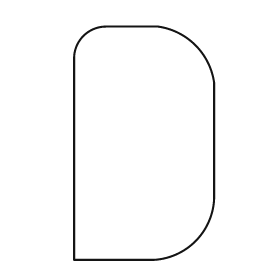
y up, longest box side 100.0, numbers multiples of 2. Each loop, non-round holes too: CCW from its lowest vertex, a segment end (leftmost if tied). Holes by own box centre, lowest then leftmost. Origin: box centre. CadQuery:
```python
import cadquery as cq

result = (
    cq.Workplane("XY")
    .moveTo(-30.0, -50.0)
    .lineTo(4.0, -50.0)
    .threePointArc((22.0, -42.0), (30.0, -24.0))
    .lineTo(30.0, 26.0)
    .threePointArc((22.0, 42.0), (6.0, 50.0))
    .lineTo(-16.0, 50.0)
    .threePointArc((-26.0, 46.0), (-30.0, 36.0))
    .close()
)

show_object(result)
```